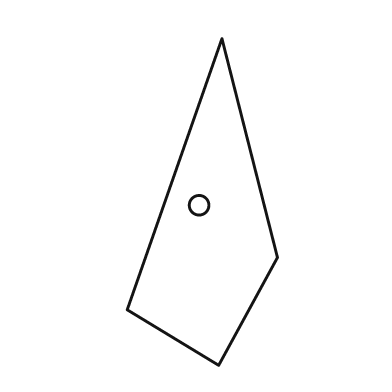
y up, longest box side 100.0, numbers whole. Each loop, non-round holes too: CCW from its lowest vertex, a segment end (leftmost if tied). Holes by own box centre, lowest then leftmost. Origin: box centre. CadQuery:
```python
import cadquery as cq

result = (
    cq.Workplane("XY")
    .moveTo(5.0, -50.0)
    .lineTo(23.0, -17.0)
    .lineTo(6.0, 50.0)
    .lineTo(-23.0, -33.0)
    .close()
    .moveTo(-1.0, -1.0)
    .circle(3.0)
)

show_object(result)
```